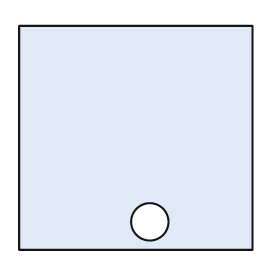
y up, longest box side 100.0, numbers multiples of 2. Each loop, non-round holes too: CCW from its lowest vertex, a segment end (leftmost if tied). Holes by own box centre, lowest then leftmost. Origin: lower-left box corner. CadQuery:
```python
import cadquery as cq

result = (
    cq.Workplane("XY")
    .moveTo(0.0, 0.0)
    .lineTo(100.0, 0.0)
    .lineTo(100.0, 96.0)
    .lineTo(0.0, 96.0)
    .close()
    .moveTo(56.0, 12.0)
    .circle(8.0)
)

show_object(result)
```